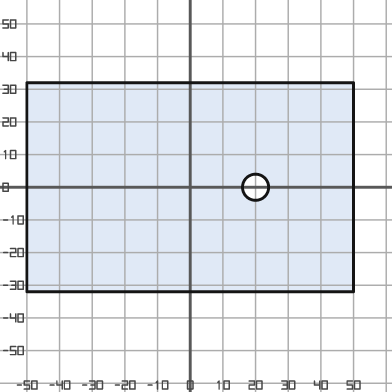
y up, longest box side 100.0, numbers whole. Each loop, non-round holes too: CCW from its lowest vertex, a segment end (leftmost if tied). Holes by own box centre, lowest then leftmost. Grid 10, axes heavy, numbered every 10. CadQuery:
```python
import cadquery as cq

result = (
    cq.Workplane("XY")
    .moveTo(-50.0, -32.0)
    .lineTo(50.0, -32.0)
    .lineTo(50.0, 32.0)
    .lineTo(-50.0, 32.0)
    .close()
    .moveTo(20.0, 0.0)
    .circle(4.0)
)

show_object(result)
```